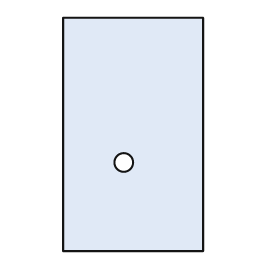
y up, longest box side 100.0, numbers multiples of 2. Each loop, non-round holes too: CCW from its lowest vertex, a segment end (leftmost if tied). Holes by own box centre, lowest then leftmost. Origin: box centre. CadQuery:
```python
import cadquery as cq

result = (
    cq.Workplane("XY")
    .moveTo(-30.0, -50.0)
    .lineTo(30.0, -50.0)
    .lineTo(30.0, 50.0)
    .lineTo(-30.0, 50.0)
    .close()
    .moveTo(-4.0, -12.0)
    .circle(4.0)
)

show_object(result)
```